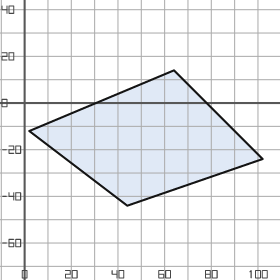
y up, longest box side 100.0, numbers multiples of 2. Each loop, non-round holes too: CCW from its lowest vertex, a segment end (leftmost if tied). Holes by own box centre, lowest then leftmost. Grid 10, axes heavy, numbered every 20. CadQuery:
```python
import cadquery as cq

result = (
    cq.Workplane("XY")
    .moveTo(44.0, -44.0)
    .lineTo(102.0, -24.0)
    .lineTo(64.0, 14.0)
    .lineTo(2.0, -12.0)
    .close()
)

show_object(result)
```